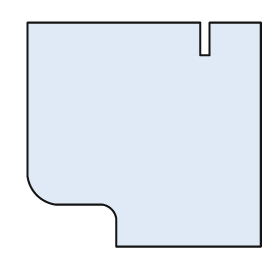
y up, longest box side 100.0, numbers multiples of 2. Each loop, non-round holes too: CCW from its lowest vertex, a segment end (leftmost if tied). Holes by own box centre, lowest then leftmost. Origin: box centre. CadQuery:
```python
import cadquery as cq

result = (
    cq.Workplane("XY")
    .moveTo(-12.0, -48.0)
    .lineTo(50.0, -48.0)
    .lineTo(50.0, 48.0)
    .lineTo(28.0, 48.0)
    .lineTo(28.0, 34.0)
    .lineTo(24.0, 34.0)
    .lineTo(24.0, 48.0)
    .lineTo(-50.0, 48.0)
    .lineTo(-50.0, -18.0)
    .threePointArc((-46.0, -26.0), (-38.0, -30.0))
    .lineTo(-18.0, -30.0)
    .threePointArc((-14.0, -32.0), (-12.0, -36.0))
    .close()
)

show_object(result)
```